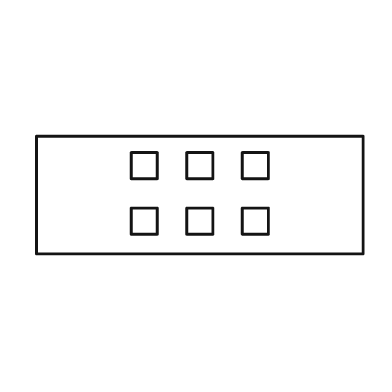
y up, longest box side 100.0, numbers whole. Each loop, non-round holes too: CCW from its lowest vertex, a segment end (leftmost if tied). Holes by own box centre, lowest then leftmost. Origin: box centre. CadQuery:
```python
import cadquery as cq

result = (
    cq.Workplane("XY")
    .moveTo(-50.0, -18.0)
    .lineTo(50.0, -18.0)
    .lineTo(50.0, 18.0)
    .lineTo(-50.0, 18.0)
    .close()
    .moveTo(-21.0, -12.0)
    .lineTo(-13.0, -12.0)
    .lineTo(-13.0, -4.0)
    .lineTo(-21.0, -4.0)
    .close()
    .moveTo(-4.0, -12.0)
    .lineTo(4.0, -12.0)
    .lineTo(4.0, -4.0)
    .lineTo(-4.0, -4.0)
    .close()
    .moveTo(13.0, -12.0)
    .lineTo(21.0, -12.0)
    .lineTo(21.0, -4.0)
    .lineTo(13.0, -4.0)
    .close()
    .moveTo(-21.0, 5.0)
    .lineTo(-13.0, 5.0)
    .lineTo(-13.0, 13.0)
    .lineTo(-21.0, 13.0)
    .close()
    .moveTo(-4.0, 5.0)
    .lineTo(4.0, 5.0)
    .lineTo(4.0, 13.0)
    .lineTo(-4.0, 13.0)
    .close()
    .moveTo(13.0, 5.0)
    .lineTo(21.0, 5.0)
    .lineTo(21.0, 13.0)
    .lineTo(13.0, 13.0)
    .close()
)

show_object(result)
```